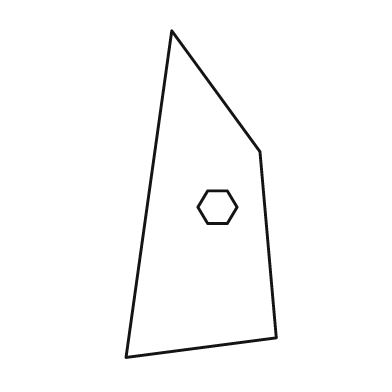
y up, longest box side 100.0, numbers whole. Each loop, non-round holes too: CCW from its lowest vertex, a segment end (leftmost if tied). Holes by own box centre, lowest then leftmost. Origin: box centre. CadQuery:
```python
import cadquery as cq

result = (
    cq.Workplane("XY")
    .moveTo(-23.0, -50.0)
    .lineTo(23.0, -44.0)
    .lineTo(18.0, 13.0)
    .lineTo(-9.0, 50.0)
    .close()
    .moveTo(2.0, -9.0)
    .lineTo(8.0, -9.0)
    .lineTo(11.0, -4.0)
    .lineTo(8.0, 1.0)
    .lineTo(2.0, 1.0)
    .lineTo(-1.0, -4.0)
    .close()
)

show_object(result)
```